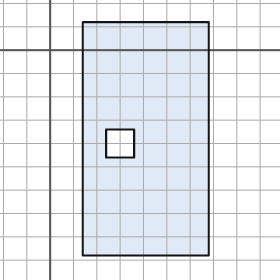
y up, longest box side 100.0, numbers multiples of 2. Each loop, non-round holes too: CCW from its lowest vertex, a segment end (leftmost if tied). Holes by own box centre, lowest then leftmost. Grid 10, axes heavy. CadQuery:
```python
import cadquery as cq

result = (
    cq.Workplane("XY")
    .moveTo(14.0, -88.0)
    .lineTo(68.0, -88.0)
    .lineTo(68.0, 12.0)
    .lineTo(14.0, 12.0)
    .close()
    .moveTo(24.0, -46.0)
    .lineTo(36.0, -46.0)
    .lineTo(36.0, -34.0)
    .lineTo(24.0, -34.0)
    .close()
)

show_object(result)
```